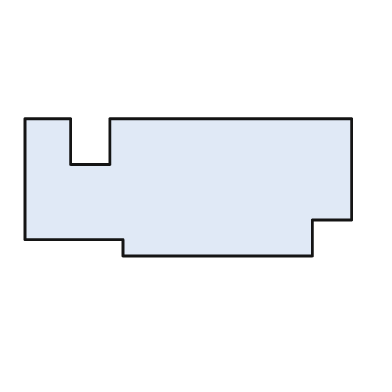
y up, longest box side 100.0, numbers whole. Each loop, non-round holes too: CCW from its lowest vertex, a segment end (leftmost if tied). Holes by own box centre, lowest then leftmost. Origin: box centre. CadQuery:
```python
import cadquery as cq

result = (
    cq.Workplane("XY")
    .moveTo(-20.0, -21.0)
    .lineTo(38.0, -21.0)
    .lineTo(38.0, -10.0)
    .lineTo(50.0, -10.0)
    .lineTo(50.0, 21.0)
    .lineTo(-24.0, 21.0)
    .lineTo(-24.0, 7.0)
    .lineTo(-36.0, 7.0)
    .lineTo(-36.0, 21.0)
    .lineTo(-50.0, 21.0)
    .lineTo(-50.0, -16.0)
    .lineTo(-20.0, -16.0)
    .close()
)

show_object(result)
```